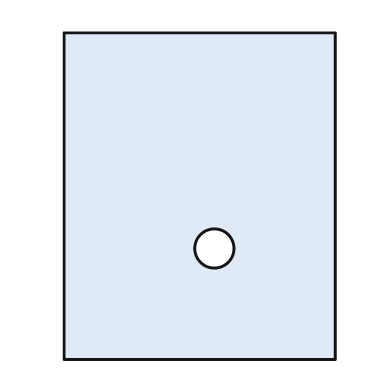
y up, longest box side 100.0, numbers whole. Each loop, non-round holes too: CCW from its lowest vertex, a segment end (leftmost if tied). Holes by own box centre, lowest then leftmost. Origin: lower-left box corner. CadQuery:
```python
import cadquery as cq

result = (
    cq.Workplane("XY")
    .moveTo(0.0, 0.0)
    .lineTo(83.0, 0.0)
    .lineTo(83.0, 100.0)
    .lineTo(0.0, 100.0)
    .close()
    .moveTo(46.0, 34.0)
    .circle(6.0)
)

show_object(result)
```